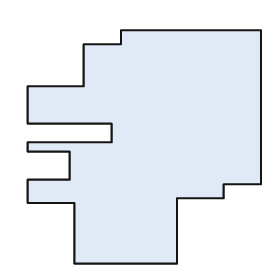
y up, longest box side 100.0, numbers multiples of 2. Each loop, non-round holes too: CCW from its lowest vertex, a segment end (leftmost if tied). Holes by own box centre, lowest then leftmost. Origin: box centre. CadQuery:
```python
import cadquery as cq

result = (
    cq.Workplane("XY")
    .moveTo(-30.0, -50.0)
    .lineTo(14.0, -50.0)
    .lineTo(14.0, -22.0)
    .lineTo(34.0, -22.0)
    .lineTo(34.0, -16.0)
    .lineTo(50.0, -16.0)
    .lineTo(50.0, 50.0)
    .lineTo(-10.0, 50.0)
    .lineTo(-10.0, 44.0)
    .lineTo(-26.0, 44.0)
    .lineTo(-26.0, 26.0)
    .lineTo(-50.0, 26.0)
    .lineTo(-50.0, 10.0)
    .lineTo(-14.0, 10.0)
    .lineTo(-14.0, 2.0)
    .lineTo(-50.0, 2.0)
    .lineTo(-50.0, -2.0)
    .lineTo(-32.0, -2.0)
    .lineTo(-32.0, -14.0)
    .lineTo(-50.0, -14.0)
    .lineTo(-50.0, -24.0)
    .lineTo(-30.0, -24.0)
    .close()
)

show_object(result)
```